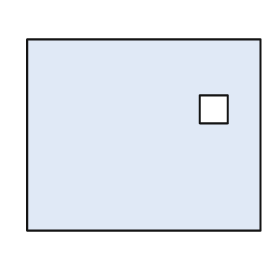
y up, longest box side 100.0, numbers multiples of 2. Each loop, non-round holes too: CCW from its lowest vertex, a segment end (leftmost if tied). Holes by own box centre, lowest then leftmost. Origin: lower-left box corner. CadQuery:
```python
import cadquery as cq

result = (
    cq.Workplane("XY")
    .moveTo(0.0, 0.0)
    .lineTo(100.0, 0.0)
    .lineTo(100.0, 82.0)
    .lineTo(0.0, 82.0)
    .close()
    .moveTo(74.0, 46.0)
    .lineTo(86.0, 46.0)
    .lineTo(86.0, 58.0)
    .lineTo(74.0, 58.0)
    .close()
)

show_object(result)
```